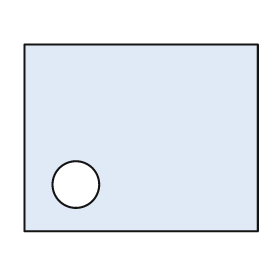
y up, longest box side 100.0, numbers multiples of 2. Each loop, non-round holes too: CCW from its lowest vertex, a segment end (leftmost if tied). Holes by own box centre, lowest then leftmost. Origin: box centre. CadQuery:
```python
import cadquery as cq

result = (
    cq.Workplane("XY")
    .moveTo(-50.0, -40.0)
    .lineTo(50.0, -40.0)
    .lineTo(50.0, 40.0)
    .lineTo(-50.0, 40.0)
    .close()
    .moveTo(-28.0, -20.0)
    .circle(10.0)
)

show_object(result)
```